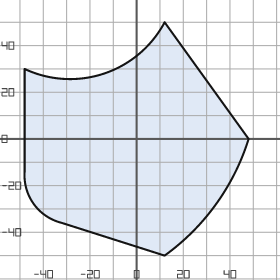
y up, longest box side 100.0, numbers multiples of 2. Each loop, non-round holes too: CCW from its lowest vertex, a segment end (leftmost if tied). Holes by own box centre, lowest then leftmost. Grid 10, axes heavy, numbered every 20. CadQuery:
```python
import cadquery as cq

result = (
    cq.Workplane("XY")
    .moveTo(12.0, -50.0)
    .threePointArc((34.0, -28.0), (48.0, 0.0))
    .lineTo(12.0, 50.0)
    .threePointArc((-14.0, 28.0), (-48.0, 30.0))
    .lineTo(-48.0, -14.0)
    .threePointArc((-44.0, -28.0), (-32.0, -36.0))
    .close()
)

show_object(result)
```